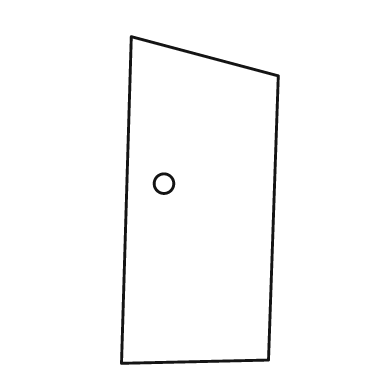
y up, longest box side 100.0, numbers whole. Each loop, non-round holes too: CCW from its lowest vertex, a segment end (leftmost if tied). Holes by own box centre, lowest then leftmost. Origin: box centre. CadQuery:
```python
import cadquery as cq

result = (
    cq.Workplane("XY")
    .moveTo(-24.0, -50.0)
    .lineTo(21.0, -49.0)
    .lineTo(24.0, 38.0)
    .lineTo(-21.0, 50.0)
    .close()
    .moveTo(-11.0, 5.0)
    .circle(3.0)
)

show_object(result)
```